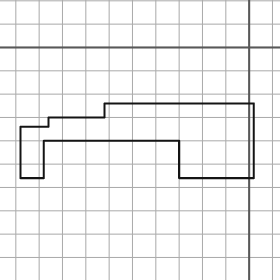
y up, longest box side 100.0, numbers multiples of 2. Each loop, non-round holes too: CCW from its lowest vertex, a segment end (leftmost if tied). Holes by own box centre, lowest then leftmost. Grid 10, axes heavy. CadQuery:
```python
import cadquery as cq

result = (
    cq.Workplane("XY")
    .moveTo(-98.0, -56.0)
    .lineTo(-88.0, -56.0)
    .lineTo(-88.0, -40.0)
    .lineTo(-30.0, -40.0)
    .lineTo(-30.0, -56.0)
    .lineTo(2.0, -56.0)
    .lineTo(2.0, -24.0)
    .lineTo(-62.0, -24.0)
    .lineTo(-62.0, -30.0)
    .lineTo(-86.0, -30.0)
    .lineTo(-86.0, -34.0)
    .lineTo(-98.0, -34.0)
    .close()
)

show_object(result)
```